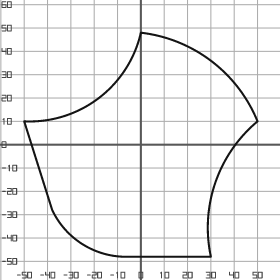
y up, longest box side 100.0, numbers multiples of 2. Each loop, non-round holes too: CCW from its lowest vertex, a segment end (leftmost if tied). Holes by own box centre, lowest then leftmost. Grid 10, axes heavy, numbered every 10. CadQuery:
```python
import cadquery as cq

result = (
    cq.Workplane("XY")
    .moveTo(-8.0, -48.0)
    .lineTo(30.0, -48.0)
    .threePointArc((32.0, -16.0), (50.0, 10.0))
    .threePointArc((30.0, 36.0), (0.0, 48.0))
    .threePointArc((-18.0, 20.0), (-50.0, 10.0))
    .lineTo(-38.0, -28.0)
    .threePointArc((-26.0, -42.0), (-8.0, -48.0))
    .close()
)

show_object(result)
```